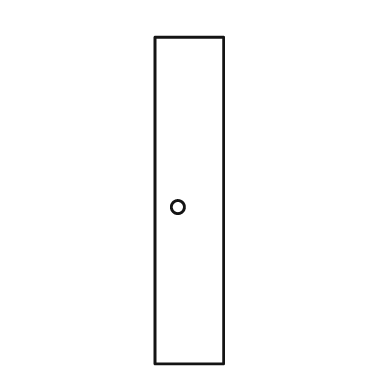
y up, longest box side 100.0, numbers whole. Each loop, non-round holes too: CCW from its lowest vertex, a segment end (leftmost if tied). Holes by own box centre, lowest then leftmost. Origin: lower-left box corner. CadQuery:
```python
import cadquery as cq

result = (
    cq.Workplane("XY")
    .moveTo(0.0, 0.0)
    .lineTo(21.0, 0.0)
    .lineTo(21.0, 100.0)
    .lineTo(0.0, 100.0)
    .close()
    .moveTo(7.0, 48.0)
    .circle(2.0)
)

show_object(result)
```